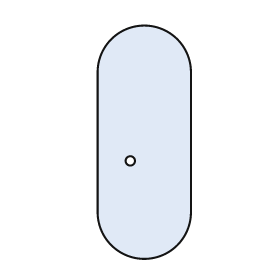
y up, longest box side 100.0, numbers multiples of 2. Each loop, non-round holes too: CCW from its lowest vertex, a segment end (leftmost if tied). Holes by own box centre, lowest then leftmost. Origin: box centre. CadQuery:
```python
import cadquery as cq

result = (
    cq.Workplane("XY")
    .moveTo(-20.0, -30.0)
    .threePointArc((0.0, -50.0), (20.0, -30.0))
    .lineTo(20.0, 30.0)
    .threePointArc((0.0, 50.0), (-20.0, 30.0))
    .close()
    .moveTo(-6.0, -8.0)
    .circle(2.0)
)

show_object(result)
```